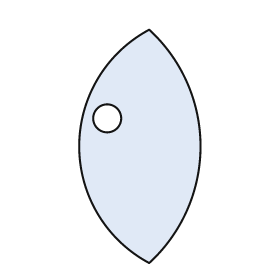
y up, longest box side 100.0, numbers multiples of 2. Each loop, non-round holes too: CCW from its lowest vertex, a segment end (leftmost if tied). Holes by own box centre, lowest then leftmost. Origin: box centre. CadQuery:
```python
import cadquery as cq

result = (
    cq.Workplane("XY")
    .moveTo(4.0, -50.0)
    .threePointArc((26.0, 0.0), (4.0, 50.0))
    .threePointArc((-26.0, 0.0), (4.0, -50.0))
    .close()
    .moveTo(-14.0, 12.0)
    .circle(6.0)
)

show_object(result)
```